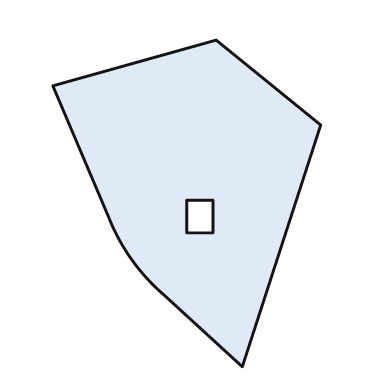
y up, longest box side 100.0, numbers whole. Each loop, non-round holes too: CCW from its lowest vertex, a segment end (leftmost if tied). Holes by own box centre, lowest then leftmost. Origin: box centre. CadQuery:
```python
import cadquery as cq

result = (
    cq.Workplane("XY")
    .moveTo(17.0, -50.0)
    .lineTo(41.0, 24.0)
    .lineTo(9.0, 50.0)
    .lineTo(-41.0, 36.0)
    .lineTo(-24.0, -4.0)
    .threePointArc((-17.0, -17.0), (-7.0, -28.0))
    .close()
    .moveTo(0.0, -9.0)
    .lineTo(8.0, -9.0)
    .lineTo(8.0, 1.0)
    .lineTo(0.0, 1.0)
    .close()
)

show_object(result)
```